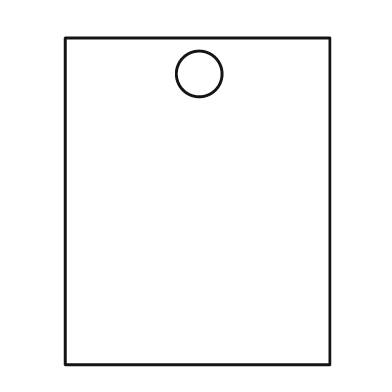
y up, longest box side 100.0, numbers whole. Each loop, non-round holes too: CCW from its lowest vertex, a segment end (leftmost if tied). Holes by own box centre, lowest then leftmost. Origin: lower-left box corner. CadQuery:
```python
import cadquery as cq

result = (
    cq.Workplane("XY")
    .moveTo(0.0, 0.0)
    .lineTo(81.0, 0.0)
    .lineTo(81.0, 100.0)
    .lineTo(0.0, 100.0)
    .close()
    .moveTo(41.0, 89.0)
    .circle(7.0)
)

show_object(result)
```